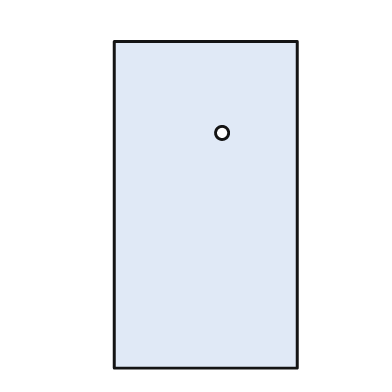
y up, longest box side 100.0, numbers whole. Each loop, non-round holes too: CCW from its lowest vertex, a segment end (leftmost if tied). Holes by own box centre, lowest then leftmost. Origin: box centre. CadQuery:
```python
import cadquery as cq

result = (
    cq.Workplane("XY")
    .moveTo(-28.0, -50.0)
    .lineTo(28.0, -50.0)
    .lineTo(28.0, 50.0)
    .lineTo(-28.0, 50.0)
    .close()
    .moveTo(5.0, 22.0)
    .circle(2.0)
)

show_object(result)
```